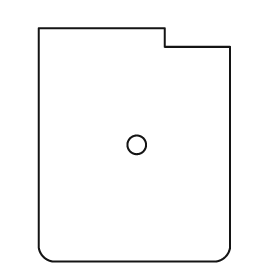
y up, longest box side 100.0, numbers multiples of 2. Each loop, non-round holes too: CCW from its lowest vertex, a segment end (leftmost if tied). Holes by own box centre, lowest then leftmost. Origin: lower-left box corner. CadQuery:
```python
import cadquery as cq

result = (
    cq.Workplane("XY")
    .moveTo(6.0, 0.0)
    .lineTo(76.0, 0.0)
    .threePointArc((80.0, 2.0), (82.0, 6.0))
    .lineTo(82.0, 92.0)
    .lineTo(54.0, 92.0)
    .lineTo(54.0, 100.0)
    .lineTo(0.0, 100.0)
    .lineTo(0.0, 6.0)
    .threePointArc((2.0, 2.0), (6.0, 0.0))
    .close()
    .moveTo(42.0, 50.0)
    .circle(4.0)
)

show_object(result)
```